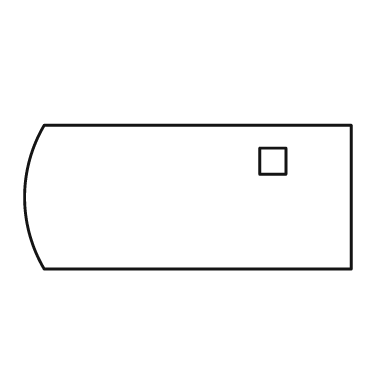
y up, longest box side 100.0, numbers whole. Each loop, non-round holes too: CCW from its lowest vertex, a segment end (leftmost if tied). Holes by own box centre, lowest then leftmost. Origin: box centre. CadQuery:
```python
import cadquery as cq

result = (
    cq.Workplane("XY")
    .moveTo(-44.0, -22.0)
    .lineTo(50.0, -22.0)
    .lineTo(50.0, 22.0)
    .lineTo(-44.0, 22.0)
    .threePointArc((-50.0, 0.0), (-44.0, -22.0))
    .close()
    .moveTo(22.0, 7.0)
    .lineTo(30.0, 7.0)
    .lineTo(30.0, 15.0)
    .lineTo(22.0, 15.0)
    .close()
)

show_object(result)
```